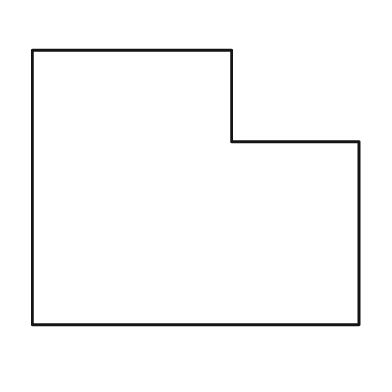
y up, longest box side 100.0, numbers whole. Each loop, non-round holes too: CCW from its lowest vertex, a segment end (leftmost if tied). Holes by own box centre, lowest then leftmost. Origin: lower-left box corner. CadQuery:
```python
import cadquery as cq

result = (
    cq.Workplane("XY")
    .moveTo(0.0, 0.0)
    .lineTo(100.0, 0.0)
    .lineTo(100.0, 56.0)
    .lineTo(61.0, 56.0)
    .lineTo(61.0, 84.0)
    .lineTo(0.0, 84.0)
    .close()
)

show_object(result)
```